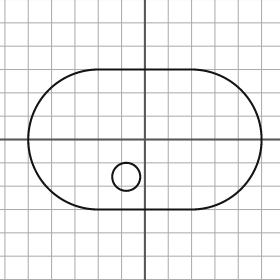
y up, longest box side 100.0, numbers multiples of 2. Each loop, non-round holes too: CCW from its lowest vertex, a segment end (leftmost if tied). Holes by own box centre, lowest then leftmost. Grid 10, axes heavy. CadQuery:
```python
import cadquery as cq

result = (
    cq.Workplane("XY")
    .moveTo(-20.0, -30.0)
    .lineTo(20.0, -30.0)
    .threePointArc((50.0, 0.0), (20.0, 30.0))
    .lineTo(-20.0, 30.0)
    .threePointArc((-50.0, 0.0), (-20.0, -30.0))
    .close()
    .moveTo(-8.0, -16.0)
    .circle(6.0)
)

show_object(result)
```